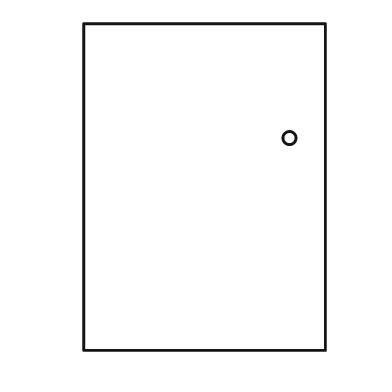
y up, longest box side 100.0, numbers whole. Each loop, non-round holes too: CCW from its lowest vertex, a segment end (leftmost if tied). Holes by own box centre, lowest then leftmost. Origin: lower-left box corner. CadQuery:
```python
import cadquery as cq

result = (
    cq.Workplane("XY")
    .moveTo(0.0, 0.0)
    .lineTo(74.0, 0.0)
    .lineTo(74.0, 100.0)
    .lineTo(0.0, 100.0)
    .close()
    .moveTo(63.0, 65.0)
    .circle(2.0)
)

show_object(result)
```